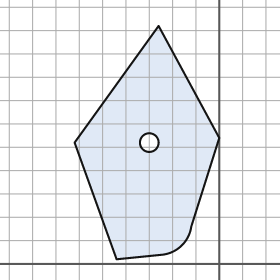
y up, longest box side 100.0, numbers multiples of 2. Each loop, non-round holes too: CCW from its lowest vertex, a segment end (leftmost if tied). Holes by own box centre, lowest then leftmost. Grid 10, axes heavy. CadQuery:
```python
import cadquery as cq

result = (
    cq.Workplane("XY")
    .moveTo(-44.0, 2.0)
    .lineTo(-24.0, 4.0)
    .threePointArc((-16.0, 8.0), (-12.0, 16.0))
    .lineTo(0.0, 54.0)
    .lineTo(-26.0, 102.0)
    .lineTo(-62.0, 52.0)
    .close()
    .moveTo(-30.0, 52.0)
    .circle(4.0)
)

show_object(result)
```